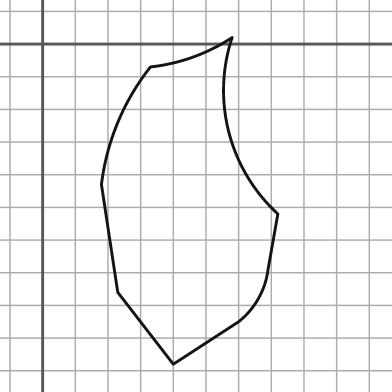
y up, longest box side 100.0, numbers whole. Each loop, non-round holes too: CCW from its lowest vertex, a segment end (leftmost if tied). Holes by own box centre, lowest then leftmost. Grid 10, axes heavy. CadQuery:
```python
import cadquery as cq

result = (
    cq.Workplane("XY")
    .moveTo(40.0, -98.0)
    .lineTo(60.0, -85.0)
    .threePointArc((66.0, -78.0), (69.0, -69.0))
    .lineTo(72.0, -52.0)
    .threePointArc((57.0, -27.0), (58.0, 2.0))
    .threePointArc((46.0, -4.0), (33.0, -7.0))
    .threePointArc((23.0, -24.0), (18.0, -43.0))
    .lineTo(23.0, -76.0)
    .close()
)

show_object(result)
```